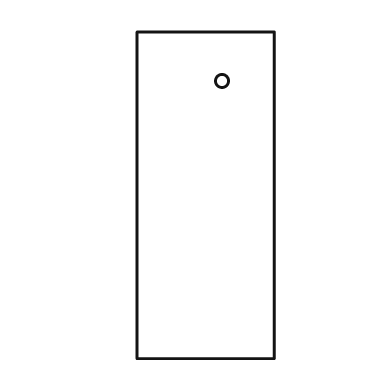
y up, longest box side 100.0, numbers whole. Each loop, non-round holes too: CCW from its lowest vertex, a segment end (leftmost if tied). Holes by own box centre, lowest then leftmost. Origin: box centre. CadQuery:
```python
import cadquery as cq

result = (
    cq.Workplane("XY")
    .moveTo(-21.0, -50.0)
    .lineTo(21.0, -50.0)
    .lineTo(21.0, 50.0)
    .lineTo(-21.0, 50.0)
    .close()
    .moveTo(5.0, 35.0)
    .circle(2.0)
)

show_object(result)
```